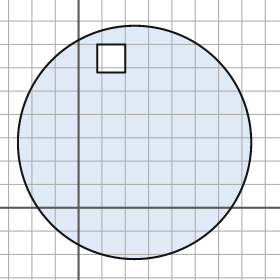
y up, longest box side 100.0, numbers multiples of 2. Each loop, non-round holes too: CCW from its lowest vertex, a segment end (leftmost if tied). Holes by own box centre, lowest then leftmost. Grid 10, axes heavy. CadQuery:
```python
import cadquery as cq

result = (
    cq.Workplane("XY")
    .moveTo(24.0, 28.0)
    .circle(50.0)
    .moveTo(8.0, 58.0)
    .lineTo(20.0, 58.0)
    .lineTo(20.0, 70.0)
    .lineTo(8.0, 70.0)
    .close()
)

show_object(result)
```